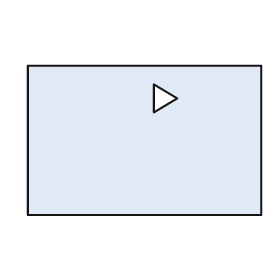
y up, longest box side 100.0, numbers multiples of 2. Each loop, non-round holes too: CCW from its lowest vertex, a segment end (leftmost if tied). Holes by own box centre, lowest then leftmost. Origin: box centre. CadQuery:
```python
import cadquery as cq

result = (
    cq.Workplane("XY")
    .moveTo(-50.0, -32.0)
    .lineTo(50.0, -32.0)
    .lineTo(50.0, 32.0)
    .lineTo(-50.0, 32.0)
    .close()
    .moveTo(4.0, 12.0)
    .lineTo(14.0, 18.0)
    .lineTo(4.0, 24.0)
    .close()
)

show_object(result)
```